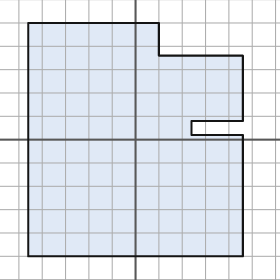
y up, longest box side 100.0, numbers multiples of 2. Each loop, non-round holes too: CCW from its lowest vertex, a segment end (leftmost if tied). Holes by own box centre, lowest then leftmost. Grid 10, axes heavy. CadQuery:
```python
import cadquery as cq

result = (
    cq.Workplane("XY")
    .moveTo(-46.0, -50.0)
    .lineTo(46.0, -50.0)
    .lineTo(46.0, 2.0)
    .lineTo(24.0, 2.0)
    .lineTo(24.0, 8.0)
    .lineTo(46.0, 8.0)
    .lineTo(46.0, 36.0)
    .lineTo(10.0, 36.0)
    .lineTo(10.0, 50.0)
    .lineTo(-46.0, 50.0)
    .close()
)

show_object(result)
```